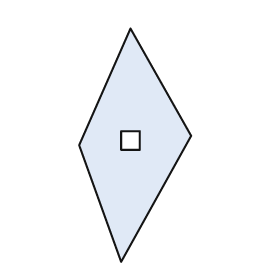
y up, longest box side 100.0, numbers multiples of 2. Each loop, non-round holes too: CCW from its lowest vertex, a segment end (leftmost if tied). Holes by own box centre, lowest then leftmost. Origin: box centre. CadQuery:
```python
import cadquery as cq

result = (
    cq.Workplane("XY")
    .moveTo(-6.0, -50.0)
    .lineTo(24.0, 4.0)
    .lineTo(-2.0, 50.0)
    .lineTo(-24.0, 0.0)
    .close()
    .moveTo(-6.0, -2.0)
    .lineTo(2.0, -2.0)
    .lineTo(2.0, 6.0)
    .lineTo(-6.0, 6.0)
    .close()
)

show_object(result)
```